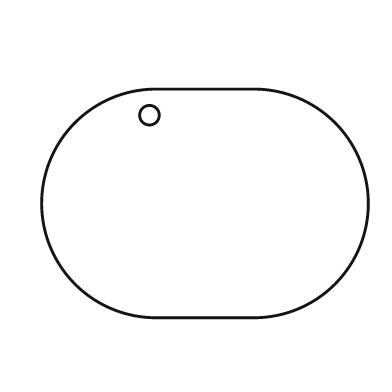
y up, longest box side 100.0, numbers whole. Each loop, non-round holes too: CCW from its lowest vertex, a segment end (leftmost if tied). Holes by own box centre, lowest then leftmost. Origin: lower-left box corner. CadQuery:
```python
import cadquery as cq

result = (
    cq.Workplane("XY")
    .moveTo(35.0, 0.0)
    .lineTo(65.0, 0.0)
    .threePointArc((100.0, 35.0), (65.0, 70.0))
    .lineTo(35.0, 70.0)
    .threePointArc((0.0, 35.0), (35.0, 0.0))
    .close()
    .moveTo(33.0, 62.0)
    .circle(3.0)
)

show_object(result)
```